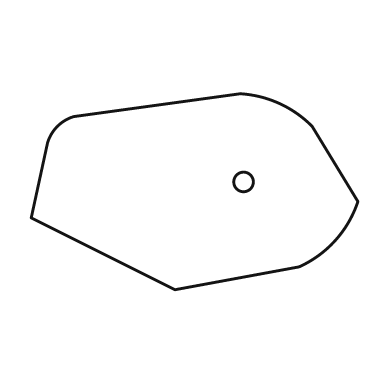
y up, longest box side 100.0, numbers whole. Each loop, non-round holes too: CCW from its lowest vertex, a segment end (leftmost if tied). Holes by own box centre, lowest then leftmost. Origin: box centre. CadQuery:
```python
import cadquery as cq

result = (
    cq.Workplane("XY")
    .moveTo(-6.0, -30.0)
    .lineTo(32.0, -23.0)
    .threePointArc((43.0, -15.0), (50.0, -3.0))
    .lineTo(36.0, 20.0)
    .threePointArc((26.0, 27.0), (14.0, 30.0))
    .lineTo(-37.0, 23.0)
    .threePointArc((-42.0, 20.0), (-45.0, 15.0))
    .lineTo(-50.0, -8.0)
    .close()
    .moveTo(15.0, 3.0)
    .circle(3.0)
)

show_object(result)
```